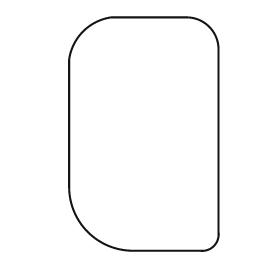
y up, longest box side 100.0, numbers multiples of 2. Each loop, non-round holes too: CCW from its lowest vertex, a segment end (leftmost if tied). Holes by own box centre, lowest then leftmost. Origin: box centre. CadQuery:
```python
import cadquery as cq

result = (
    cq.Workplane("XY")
    .moveTo(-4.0, -50.0)
    .lineTo(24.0, -50.0)
    .threePointArc((30.0, -48.0), (32.0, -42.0))
    .lineTo(32.0, 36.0)
    .threePointArc((28.0, 46.0), (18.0, 50.0))
    .lineTo(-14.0, 50.0)
    .threePointArc((-26.0, 44.0), (-32.0, 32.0))
    .lineTo(-32.0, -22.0)
    .threePointArc((-24.0, -42.0), (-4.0, -50.0))
    .close()
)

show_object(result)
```